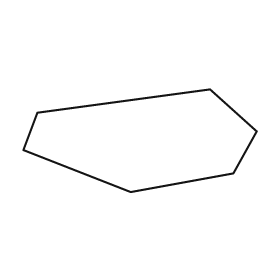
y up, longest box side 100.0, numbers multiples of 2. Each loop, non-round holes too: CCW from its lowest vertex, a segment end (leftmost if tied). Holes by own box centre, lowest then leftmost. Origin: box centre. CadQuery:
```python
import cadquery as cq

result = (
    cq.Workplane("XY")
    .moveTo(-4.0, -22.0)
    .lineTo(40.0, -14.0)
    .lineTo(50.0, 4.0)
    .lineTo(30.0, 22.0)
    .lineTo(-44.0, 12.0)
    .lineTo(-50.0, -4.0)
    .close()
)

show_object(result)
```